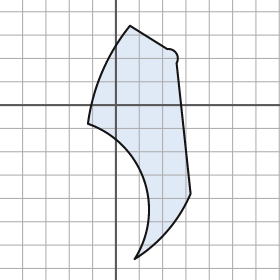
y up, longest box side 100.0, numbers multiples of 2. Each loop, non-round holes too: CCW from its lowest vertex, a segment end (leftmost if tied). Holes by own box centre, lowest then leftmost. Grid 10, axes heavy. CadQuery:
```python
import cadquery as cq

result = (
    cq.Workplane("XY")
    .moveTo(8.0, -66.0)
    .threePointArc((22.0, -54.0), (32.0, -38.0))
    .lineTo(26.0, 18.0)
    .threePointArc((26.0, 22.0), (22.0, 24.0))
    .lineTo(6.0, 34.0)
    .threePointArc((-6.0, 14.0), (-12.0, -8.0))
    .threePointArc((12.0, -32.0), (8.0, -66.0))
    .close()
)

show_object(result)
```